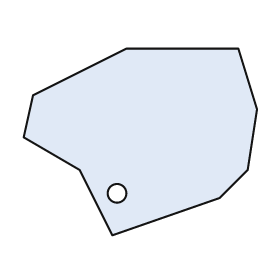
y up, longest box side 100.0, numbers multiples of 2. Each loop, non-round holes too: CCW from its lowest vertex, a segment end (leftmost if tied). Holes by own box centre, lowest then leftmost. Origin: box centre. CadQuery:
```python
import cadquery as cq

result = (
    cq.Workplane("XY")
    .moveTo(-12.0, -40.0)
    .lineTo(34.0, -24.0)
    .lineTo(46.0, -12.0)
    .lineTo(50.0, 14.0)
    .lineTo(42.0, 40.0)
    .lineTo(-6.0, 40.0)
    .lineTo(-46.0, 20.0)
    .lineTo(-50.0, 2.0)
    .lineTo(-26.0, -12.0)
    .close()
    .moveTo(-10.0, -22.0)
    .circle(4.0)
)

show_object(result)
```